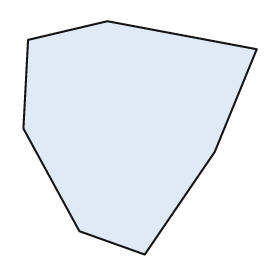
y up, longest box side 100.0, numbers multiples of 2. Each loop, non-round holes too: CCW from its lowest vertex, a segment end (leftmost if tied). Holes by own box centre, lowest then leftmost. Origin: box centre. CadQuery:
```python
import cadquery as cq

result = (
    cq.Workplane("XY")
    .moveTo(2.0, -50.0)
    .lineTo(32.0, -6.0)
    .lineTo(50.0, 38.0)
    .lineTo(-14.0, 50.0)
    .lineTo(-48.0, 42.0)
    .lineTo(-50.0, 4.0)
    .lineTo(-26.0, -40.0)
    .close()
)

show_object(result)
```